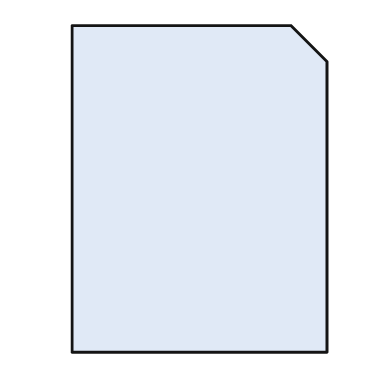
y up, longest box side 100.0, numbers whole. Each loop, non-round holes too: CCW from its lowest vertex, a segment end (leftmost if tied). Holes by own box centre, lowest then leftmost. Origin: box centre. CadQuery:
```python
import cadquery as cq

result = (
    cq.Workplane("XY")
    .moveTo(-39.0, -50.0)
    .lineTo(39.0, -50.0)
    .lineTo(39.0, 39.0)
    .lineTo(28.0, 50.0)
    .lineTo(-39.0, 50.0)
    .close()
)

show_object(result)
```